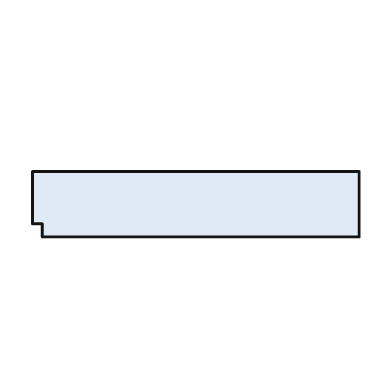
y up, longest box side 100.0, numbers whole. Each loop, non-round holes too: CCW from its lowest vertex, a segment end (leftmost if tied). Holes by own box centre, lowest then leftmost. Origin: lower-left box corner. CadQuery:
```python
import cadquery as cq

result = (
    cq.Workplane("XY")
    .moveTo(3.0, 0.0)
    .lineTo(100.0, 0.0)
    .lineTo(100.0, 20.0)
    .lineTo(0.0, 20.0)
    .lineTo(0.0, 4.0)
    .lineTo(3.0, 4.0)
    .close()
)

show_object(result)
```